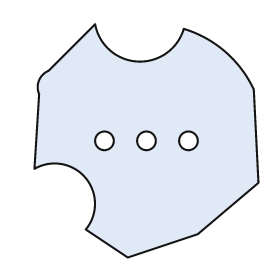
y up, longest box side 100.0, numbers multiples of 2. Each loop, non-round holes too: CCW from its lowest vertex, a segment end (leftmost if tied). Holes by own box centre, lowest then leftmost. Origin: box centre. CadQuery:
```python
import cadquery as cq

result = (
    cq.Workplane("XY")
    .moveTo(-8.0, -50.0)
    .lineTo(22.0, -40.0)
    .lineTo(48.0, -18.0)
    .lineTo(46.0, 22.0)
    .threePointArc((34.0, 38.0), (16.0, 48.0))
    .threePointArc((-4.0, 34.0), (-22.0, 50.0))
    .lineTo(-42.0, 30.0)
    .threePointArc((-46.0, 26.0), (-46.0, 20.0))
    .lineTo(-48.0, -12.0)
    .threePointArc((-26.0, -16.0), (-26.0, -38.0))
    .close()
    .moveTo(-18.0, 0.0)
    .circle(4.0)
    .moveTo(0.0, 0.0)
    .circle(4.0)
    .moveTo(18.0, 0.0)
    .circle(4.0)
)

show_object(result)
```